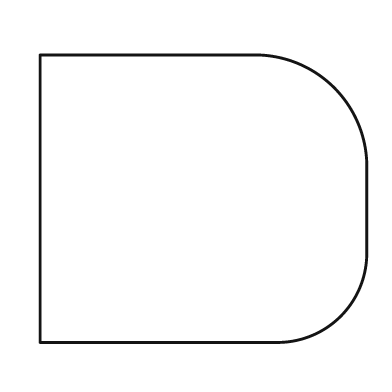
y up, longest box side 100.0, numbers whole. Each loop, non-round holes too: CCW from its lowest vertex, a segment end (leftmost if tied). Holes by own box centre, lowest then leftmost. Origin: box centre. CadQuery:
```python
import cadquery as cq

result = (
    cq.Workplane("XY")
    .moveTo(-50.0, -44.0)
    .lineTo(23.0, -44.0)
    .threePointArc((42.0, -36.0), (50.0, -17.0))
    .lineTo(50.0, 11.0)
    .threePointArc((40.0, 34.0), (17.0, 44.0))
    .lineTo(-50.0, 44.0)
    .close()
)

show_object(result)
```